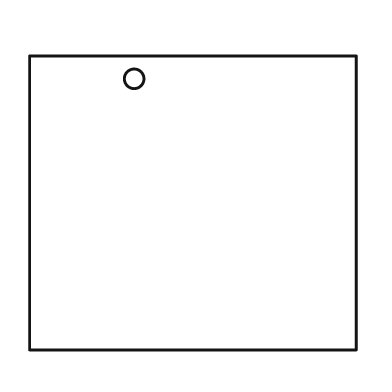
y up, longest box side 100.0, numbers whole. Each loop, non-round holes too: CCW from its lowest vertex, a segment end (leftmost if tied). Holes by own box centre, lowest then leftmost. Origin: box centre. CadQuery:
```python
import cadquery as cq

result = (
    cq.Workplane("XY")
    .moveTo(-50.0, -45.0)
    .lineTo(50.0, -45.0)
    .lineTo(50.0, 45.0)
    .lineTo(-50.0, 45.0)
    .close()
    .moveTo(-18.0, 38.0)
    .circle(3.0)
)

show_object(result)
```